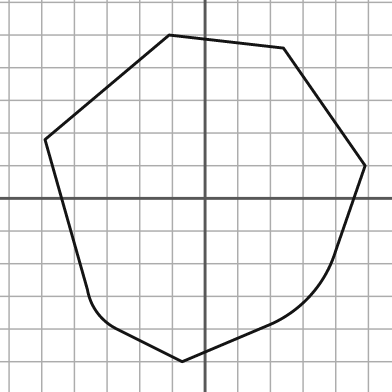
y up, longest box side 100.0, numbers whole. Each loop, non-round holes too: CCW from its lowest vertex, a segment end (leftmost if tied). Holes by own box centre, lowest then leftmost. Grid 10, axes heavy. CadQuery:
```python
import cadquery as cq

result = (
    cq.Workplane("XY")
    .moveTo(-7.0, -50.0)
    .lineTo(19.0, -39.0)
    .threePointArc((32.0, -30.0), (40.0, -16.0))
    .lineTo(49.0, 10.0)
    .lineTo(24.0, 46.0)
    .lineTo(-11.0, 50.0)
    .lineTo(-49.0, 18.0)
    .lineTo(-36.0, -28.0)
    .threePointArc((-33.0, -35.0), (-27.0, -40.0))
    .close()
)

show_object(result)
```